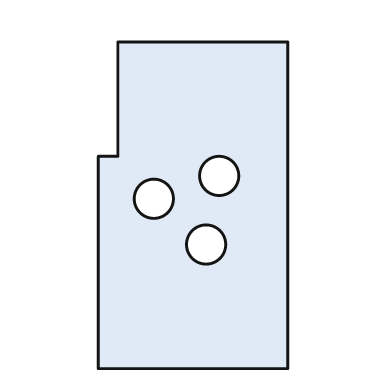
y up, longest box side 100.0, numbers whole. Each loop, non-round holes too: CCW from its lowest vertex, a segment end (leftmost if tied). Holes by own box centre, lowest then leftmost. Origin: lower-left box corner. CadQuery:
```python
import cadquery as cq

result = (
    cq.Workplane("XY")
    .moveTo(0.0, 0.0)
    .lineTo(58.0, 0.0)
    .lineTo(58.0, 100.0)
    .lineTo(6.0, 100.0)
    .lineTo(6.0, 65.0)
    .lineTo(0.0, 65.0)
    .close()
    .moveTo(33.0, 38.0)
    .circle(6.0)
    .moveTo(17.0, 52.0)
    .circle(6.0)
    .moveTo(37.0, 59.0)
    .circle(6.0)
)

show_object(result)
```